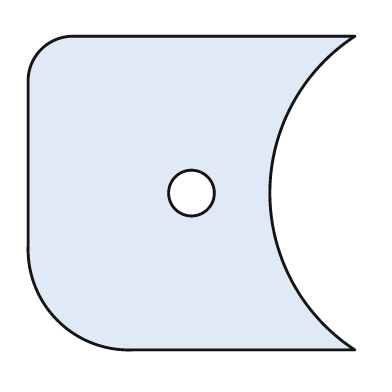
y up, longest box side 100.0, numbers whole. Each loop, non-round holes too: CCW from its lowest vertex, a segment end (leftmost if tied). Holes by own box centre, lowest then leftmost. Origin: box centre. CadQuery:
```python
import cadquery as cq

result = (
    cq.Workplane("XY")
    .moveTo(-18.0, -48.0)
    .lineTo(50.0, -48.0)
    .threePointArc((24.0, 0.0), (50.0, 48.0))
    .lineTo(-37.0, 48.0)
    .threePointArc((-46.0, 44.0), (-50.0, 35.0))
    .lineTo(-50.0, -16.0)
    .threePointArc((-41.0, -39.0), (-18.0, -48.0))
    .close()
    .moveTo(0.0, 0.0)
    .circle(7.0)
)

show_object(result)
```